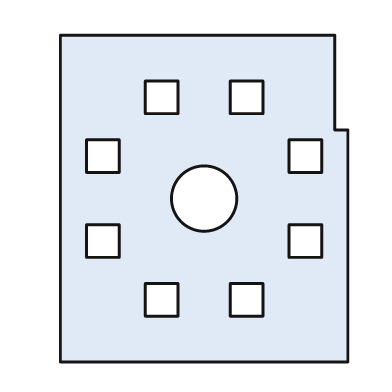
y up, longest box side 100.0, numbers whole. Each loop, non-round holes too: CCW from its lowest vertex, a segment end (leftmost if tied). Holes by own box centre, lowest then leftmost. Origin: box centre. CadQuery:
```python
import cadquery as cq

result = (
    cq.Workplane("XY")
    .moveTo(-44.0, -50.0)
    .lineTo(44.0, -50.0)
    .lineTo(44.0, 21.0)
    .lineTo(40.0, 21.0)
    .lineTo(40.0, 50.0)
    .lineTo(-44.0, 50.0)
    .close()
    .moveTo(-18.0, -36.0)
    .lineTo(-8.0, -36.0)
    .lineTo(-8.0, -26.0)
    .lineTo(-18.0, -26.0)
    .close()
    .moveTo(8.0, -36.0)
    .lineTo(18.0, -36.0)
    .lineTo(18.0, -26.0)
    .lineTo(8.0, -26.0)
    .close()
    .moveTo(-36.0, -18.0)
    .lineTo(-26.0, -18.0)
    .lineTo(-26.0, -8.0)
    .lineTo(-36.0, -8.0)
    .close()
    .moveTo(26.0, -18.0)
    .lineTo(36.0, -18.0)
    .lineTo(36.0, -8.0)
    .lineTo(26.0, -8.0)
    .close()
    .moveTo(0.0, 0.0)
    .circle(10.0)
    .moveTo(-36.0, 8.0)
    .lineTo(-26.0, 8.0)
    .lineTo(-26.0, 18.0)
    .lineTo(-36.0, 18.0)
    .close()
    .moveTo(26.0, 8.0)
    .lineTo(36.0, 8.0)
    .lineTo(36.0, 18.0)
    .lineTo(26.0, 18.0)
    .close()
    .moveTo(-18.0, 26.0)
    .lineTo(-8.0, 26.0)
    .lineTo(-8.0, 36.0)
    .lineTo(-18.0, 36.0)
    .close()
    .moveTo(8.0, 26.0)
    .lineTo(18.0, 26.0)
    .lineTo(18.0, 36.0)
    .lineTo(8.0, 36.0)
    .close()
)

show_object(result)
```